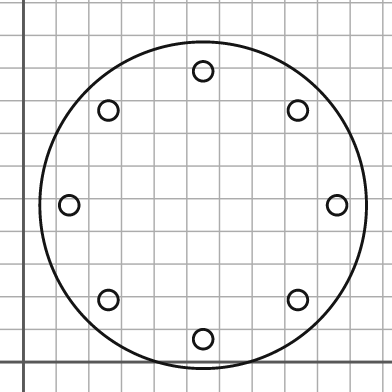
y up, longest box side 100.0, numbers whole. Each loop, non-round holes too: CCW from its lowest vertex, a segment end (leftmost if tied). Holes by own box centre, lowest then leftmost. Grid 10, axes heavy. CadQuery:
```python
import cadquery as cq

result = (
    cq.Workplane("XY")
    .moveTo(55.0, 48.0)
    .circle(50.0)
    .moveTo(55.0, 7.0)
    .circle(3.0)
    .moveTo(26.0, 19.0)
    .circle(3.0)
    .moveTo(84.0, 19.0)
    .circle(3.0)
    .moveTo(14.0, 48.0)
    .circle(3.0)
    .moveTo(96.0, 48.0)
    .circle(3.0)
    .moveTo(26.0, 77.0)
    .circle(3.0)
    .moveTo(84.0, 77.0)
    .circle(3.0)
    .moveTo(55.0, 89.0)
    .circle(3.0)
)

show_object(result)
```